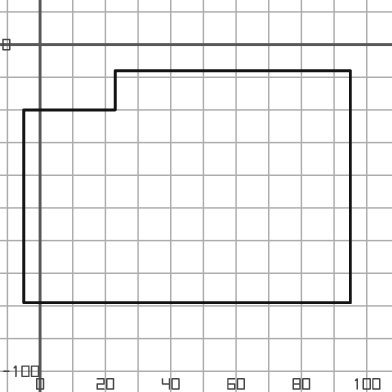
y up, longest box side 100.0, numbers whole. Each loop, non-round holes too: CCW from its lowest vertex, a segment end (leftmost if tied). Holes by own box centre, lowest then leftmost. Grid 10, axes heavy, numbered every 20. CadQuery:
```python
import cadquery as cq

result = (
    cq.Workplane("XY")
    .moveTo(-5.0, -79.0)
    .lineTo(95.0, -79.0)
    .lineTo(95.0, -8.0)
    .lineTo(23.0, -8.0)
    .lineTo(23.0, -20.0)
    .lineTo(-5.0, -20.0)
    .close()
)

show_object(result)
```